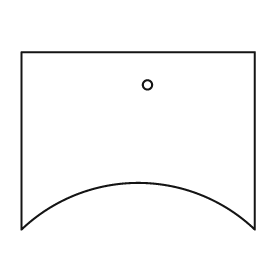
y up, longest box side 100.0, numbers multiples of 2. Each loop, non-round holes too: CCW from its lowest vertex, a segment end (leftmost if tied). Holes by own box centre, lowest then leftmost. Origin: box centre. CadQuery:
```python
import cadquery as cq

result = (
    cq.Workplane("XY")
    .moveTo(-50.0, -38.0)
    .threePointArc((0.0, -18.0), (50.0, -38.0))
    .lineTo(50.0, 38.0)
    .lineTo(-50.0, 38.0)
    .close()
    .moveTo(4.0, 24.0)
    .circle(2.0)
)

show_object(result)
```